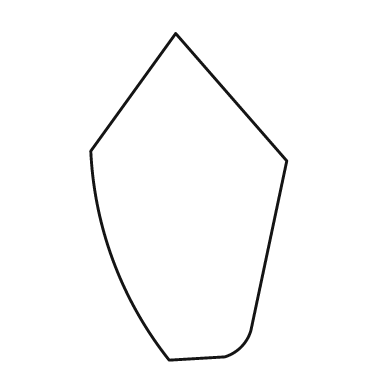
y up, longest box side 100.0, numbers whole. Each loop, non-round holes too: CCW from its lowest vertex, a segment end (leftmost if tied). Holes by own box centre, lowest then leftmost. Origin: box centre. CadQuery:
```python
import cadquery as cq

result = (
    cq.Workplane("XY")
    .moveTo(-6.0, -50.0)
    .lineTo(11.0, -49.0)
    .threePointArc((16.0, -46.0), (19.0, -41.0))
    .lineTo(30.0, 11.0)
    .lineTo(-4.0, 50.0)
    .lineTo(-30.0, 14.0)
    .threePointArc((-23.0, -20.0), (-6.0, -50.0))
    .close()
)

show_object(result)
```